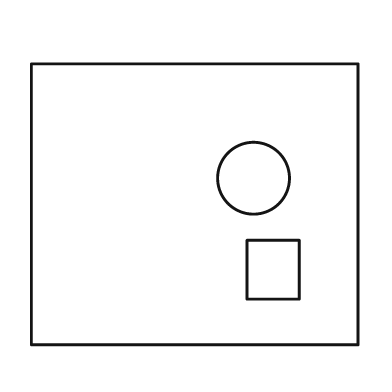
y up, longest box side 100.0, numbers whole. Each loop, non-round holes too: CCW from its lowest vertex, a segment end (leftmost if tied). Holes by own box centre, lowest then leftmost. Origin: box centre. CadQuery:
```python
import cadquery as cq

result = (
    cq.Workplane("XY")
    .moveTo(-50.0, -43.0)
    .lineTo(50.0, -43.0)
    .lineTo(50.0, 43.0)
    .lineTo(-50.0, 43.0)
    .close()
    .moveTo(16.0, -29.0)
    .lineTo(32.0, -29.0)
    .lineTo(32.0, -11.0)
    .lineTo(16.0, -11.0)
    .close()
    .moveTo(18.0, 8.0)
    .circle(11.0)
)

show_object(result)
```